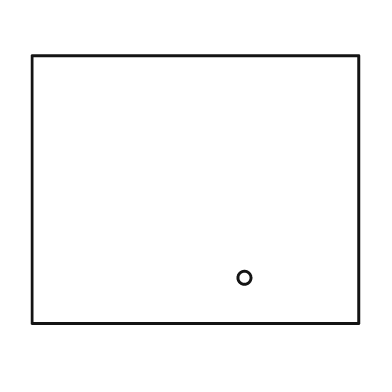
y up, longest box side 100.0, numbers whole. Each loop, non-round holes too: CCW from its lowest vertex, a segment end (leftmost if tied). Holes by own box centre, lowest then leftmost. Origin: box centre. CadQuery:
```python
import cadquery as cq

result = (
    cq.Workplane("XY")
    .moveTo(-50.0, -41.0)
    .lineTo(50.0, -41.0)
    .lineTo(50.0, 41.0)
    .lineTo(-50.0, 41.0)
    .close()
    .moveTo(15.0, -27.0)
    .circle(2.0)
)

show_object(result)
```